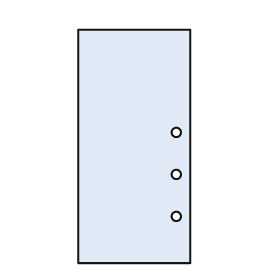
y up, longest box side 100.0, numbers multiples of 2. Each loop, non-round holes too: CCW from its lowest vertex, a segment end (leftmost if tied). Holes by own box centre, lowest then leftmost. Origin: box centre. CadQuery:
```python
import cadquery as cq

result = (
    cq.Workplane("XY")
    .moveTo(-24.0, -50.0)
    .lineTo(24.0, -50.0)
    .lineTo(24.0, 50.0)
    .lineTo(-24.0, 50.0)
    .close()
    .moveTo(18.0, -30.0)
    .circle(2.0)
    .moveTo(18.0, -12.0)
    .circle(2.0)
    .moveTo(18.0, 6.0)
    .circle(2.0)
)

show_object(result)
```